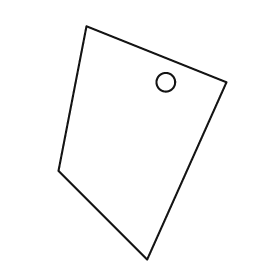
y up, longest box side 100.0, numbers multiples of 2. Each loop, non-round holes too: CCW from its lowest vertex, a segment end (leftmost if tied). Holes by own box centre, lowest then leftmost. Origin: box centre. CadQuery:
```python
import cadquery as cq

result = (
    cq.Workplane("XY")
    .moveTo(2.0, -50.0)
    .lineTo(36.0, 26.0)
    .lineTo(-24.0, 50.0)
    .lineTo(-36.0, -12.0)
    .close()
    .moveTo(10.0, 26.0)
    .circle(4.0)
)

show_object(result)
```